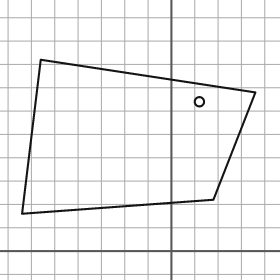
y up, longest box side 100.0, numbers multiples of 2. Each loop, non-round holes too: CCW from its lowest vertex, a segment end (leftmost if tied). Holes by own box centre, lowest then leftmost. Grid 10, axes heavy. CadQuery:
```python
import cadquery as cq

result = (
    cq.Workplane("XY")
    .moveTo(-64.0, 16.0)
    .lineTo(18.0, 22.0)
    .lineTo(36.0, 68.0)
    .lineTo(-56.0, 82.0)
    .close()
    .moveTo(12.0, 64.0)
    .circle(2.0)
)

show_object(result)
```